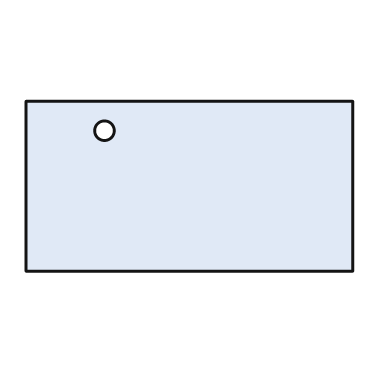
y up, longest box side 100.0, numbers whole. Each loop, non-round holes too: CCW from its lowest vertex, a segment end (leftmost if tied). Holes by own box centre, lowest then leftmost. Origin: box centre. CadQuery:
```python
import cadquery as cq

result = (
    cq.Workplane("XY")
    .moveTo(-50.0, -26.0)
    .lineTo(50.0, -26.0)
    .lineTo(50.0, 26.0)
    .lineTo(-50.0, 26.0)
    .close()
    .moveTo(-26.0, 17.0)
    .circle(3.0)
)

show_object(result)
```